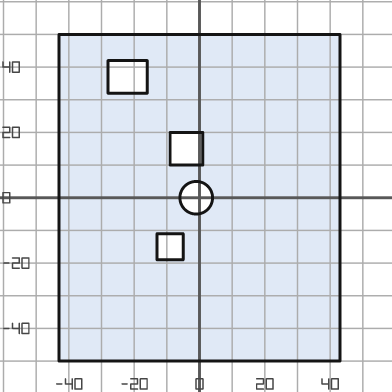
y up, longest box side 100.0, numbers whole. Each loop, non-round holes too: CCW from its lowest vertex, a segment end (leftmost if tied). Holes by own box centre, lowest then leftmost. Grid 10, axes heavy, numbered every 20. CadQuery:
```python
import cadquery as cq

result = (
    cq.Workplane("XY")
    .moveTo(-43.0, -50.0)
    .lineTo(43.0, -50.0)
    .lineTo(43.0, 50.0)
    .lineTo(-43.0, 50.0)
    .close()
    .moveTo(-13.0, -19.0)
    .lineTo(-5.0, -19.0)
    .lineTo(-5.0, -11.0)
    .lineTo(-13.0, -11.0)
    .close()
    .moveTo(-1.0, 0.0)
    .circle(5.0)
    .moveTo(-9.0, 10.0)
    .lineTo(1.0, 10.0)
    .lineTo(1.0, 20.0)
    .lineTo(-9.0, 20.0)
    .close()
    .moveTo(-28.0, 32.0)
    .lineTo(-16.0, 32.0)
    .lineTo(-16.0, 42.0)
    .lineTo(-28.0, 42.0)
    .close()
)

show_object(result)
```